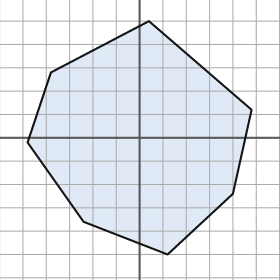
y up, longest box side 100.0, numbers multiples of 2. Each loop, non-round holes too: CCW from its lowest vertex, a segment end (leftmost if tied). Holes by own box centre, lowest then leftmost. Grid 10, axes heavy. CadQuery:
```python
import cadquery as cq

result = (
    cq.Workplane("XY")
    .moveTo(12.0, -50.0)
    .lineTo(40.0, -24.0)
    .lineTo(48.0, 12.0)
    .lineTo(4.0, 50.0)
    .lineTo(-38.0, 28.0)
    .lineTo(-48.0, -2.0)
    .lineTo(-24.0, -36.0)
    .close()
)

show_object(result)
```